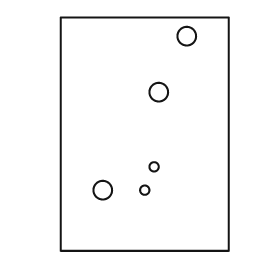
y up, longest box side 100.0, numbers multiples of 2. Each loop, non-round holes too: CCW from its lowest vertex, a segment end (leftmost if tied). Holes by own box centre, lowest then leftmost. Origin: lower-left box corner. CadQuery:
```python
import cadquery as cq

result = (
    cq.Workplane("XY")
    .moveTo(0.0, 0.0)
    .lineTo(72.0, 0.0)
    .lineTo(72.0, 100.0)
    .lineTo(0.0, 100.0)
    .close()
    .moveTo(18.0, 26.0)
    .circle(4.0)
    .moveTo(36.0, 26.0)
    .circle(2.0)
    .moveTo(40.0, 36.0)
    .circle(2.0)
    .moveTo(42.0, 68.0)
    .circle(4.0)
    .moveTo(54.0, 92.0)
    .circle(4.0)
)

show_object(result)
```